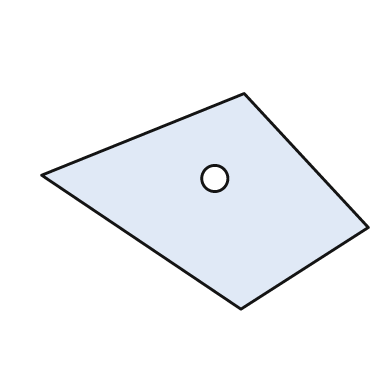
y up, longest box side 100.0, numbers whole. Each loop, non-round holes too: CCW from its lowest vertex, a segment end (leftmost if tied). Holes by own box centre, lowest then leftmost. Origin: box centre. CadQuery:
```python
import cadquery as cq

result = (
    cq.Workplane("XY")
    .moveTo(11.0, -33.0)
    .lineTo(50.0, -8.0)
    .lineTo(12.0, 33.0)
    .lineTo(-50.0, 8.0)
    .close()
    .moveTo(3.0, 7.0)
    .circle(4.0)
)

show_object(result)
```